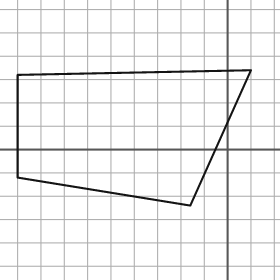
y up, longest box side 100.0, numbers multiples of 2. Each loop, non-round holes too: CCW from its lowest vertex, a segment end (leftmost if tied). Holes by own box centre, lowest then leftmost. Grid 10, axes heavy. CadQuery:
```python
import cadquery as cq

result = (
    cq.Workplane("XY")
    .moveTo(-16.0, -24.0)
    .lineTo(10.0, 34.0)
    .lineTo(-90.0, 32.0)
    .lineTo(-90.0, -12.0)
    .close()
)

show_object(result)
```